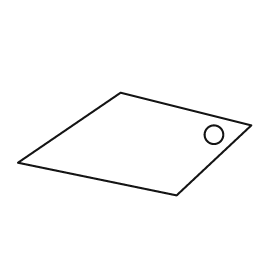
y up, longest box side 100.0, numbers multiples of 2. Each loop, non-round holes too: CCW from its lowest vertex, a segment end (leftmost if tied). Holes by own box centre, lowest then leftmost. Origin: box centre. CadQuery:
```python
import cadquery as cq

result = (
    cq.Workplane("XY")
    .moveTo(18.0, -22.0)
    .lineTo(50.0, 8.0)
    .lineTo(-6.0, 22.0)
    .lineTo(-50.0, -8.0)
    .close()
    .moveTo(34.0, 4.0)
    .circle(4.0)
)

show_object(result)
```